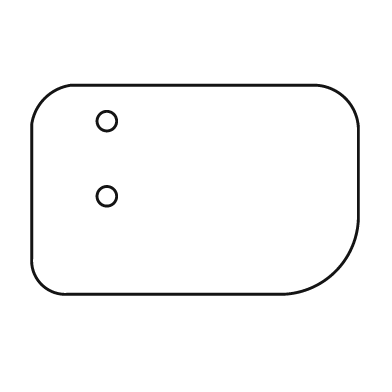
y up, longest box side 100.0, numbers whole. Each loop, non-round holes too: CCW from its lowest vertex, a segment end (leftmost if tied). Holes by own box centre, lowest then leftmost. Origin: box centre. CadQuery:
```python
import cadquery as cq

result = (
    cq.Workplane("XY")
    .moveTo(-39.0, -32.0)
    .lineTo(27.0, -32.0)
    .threePointArc((43.0, -25.0), (50.0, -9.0))
    .lineTo(50.0, 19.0)
    .threePointArc((46.0, 28.0), (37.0, 32.0))
    .lineTo(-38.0, 32.0)
    .threePointArc((-46.0, 28.0), (-50.0, 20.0))
    .lineTo(-50.0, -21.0)
    .threePointArc((-47.0, -29.0), (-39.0, -32.0))
    .close()
    .moveTo(-27.0, -2.0)
    .circle(3.0)
    .moveTo(-27.0, 21.0)
    .circle(3.0)
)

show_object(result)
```